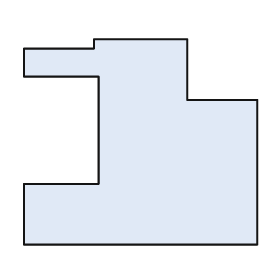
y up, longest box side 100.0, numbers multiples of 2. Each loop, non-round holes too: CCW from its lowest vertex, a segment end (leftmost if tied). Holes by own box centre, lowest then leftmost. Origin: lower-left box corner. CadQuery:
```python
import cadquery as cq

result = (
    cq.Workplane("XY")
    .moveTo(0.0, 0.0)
    .lineTo(100.0, 0.0)
    .lineTo(100.0, 62.0)
    .lineTo(70.0, 62.0)
    .lineTo(70.0, 88.0)
    .lineTo(30.0, 88.0)
    .lineTo(30.0, 84.0)
    .lineTo(0.0, 84.0)
    .lineTo(0.0, 72.0)
    .lineTo(32.0, 72.0)
    .lineTo(32.0, 26.0)
    .lineTo(0.0, 26.0)
    .close()
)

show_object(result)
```